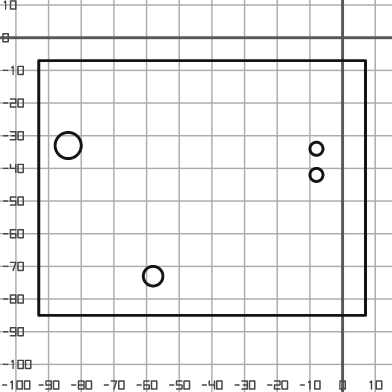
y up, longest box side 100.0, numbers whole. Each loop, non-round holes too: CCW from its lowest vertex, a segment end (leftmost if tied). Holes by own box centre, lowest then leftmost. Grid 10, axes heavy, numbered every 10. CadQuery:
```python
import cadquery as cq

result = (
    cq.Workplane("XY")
    .moveTo(-93.0, -85.0)
    .lineTo(7.0, -85.0)
    .lineTo(7.0, -7.0)
    .lineTo(-93.0, -7.0)
    .close()
    .moveTo(-58.0, -73.0)
    .circle(3.0)
    .moveTo(-8.0, -42.0)
    .circle(2.0)
    .moveTo(-8.0, -34.0)
    .circle(2.0)
    .moveTo(-84.0, -33.0)
    .circle(4.0)
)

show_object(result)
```